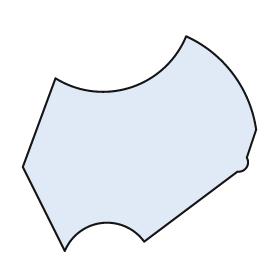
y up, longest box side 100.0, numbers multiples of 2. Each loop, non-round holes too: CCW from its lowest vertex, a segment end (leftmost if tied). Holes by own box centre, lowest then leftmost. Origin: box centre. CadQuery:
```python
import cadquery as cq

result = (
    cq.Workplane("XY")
    .moveTo(-32.0, -46.0)
    .threePointArc((-16.0, -34.0), (2.0, -42.0))
    .lineTo(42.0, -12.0)
    .threePointArc((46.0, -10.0), (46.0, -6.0))
    .lineTo(50.0, 6.0)
    .threePointArc((40.0, 30.0), (20.0, 46.0))
    .threePointArc((-4.0, 24.0), (-36.0, 28.0))
    .lineTo(-50.0, -10.0)
    .close()
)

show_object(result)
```